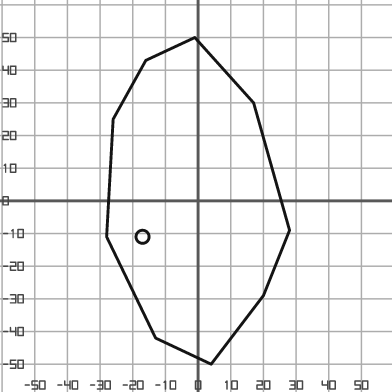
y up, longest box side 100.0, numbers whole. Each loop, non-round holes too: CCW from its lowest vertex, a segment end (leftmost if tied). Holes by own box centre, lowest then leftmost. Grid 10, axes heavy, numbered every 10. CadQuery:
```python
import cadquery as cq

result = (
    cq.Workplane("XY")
    .moveTo(4.0, -50.0)
    .lineTo(20.0, -29.0)
    .lineTo(28.0, -9.0)
    .lineTo(17.0, 30.0)
    .lineTo(-1.0, 50.0)
    .lineTo(-16.0, 43.0)
    .lineTo(-26.0, 25.0)
    .lineTo(-28.0, -11.0)
    .lineTo(-13.0, -42.0)
    .close()
    .moveTo(-17.0, -11.0)
    .circle(2.0)
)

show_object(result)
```